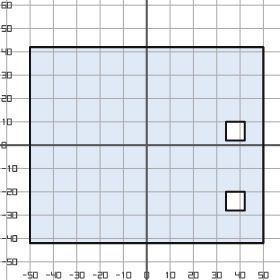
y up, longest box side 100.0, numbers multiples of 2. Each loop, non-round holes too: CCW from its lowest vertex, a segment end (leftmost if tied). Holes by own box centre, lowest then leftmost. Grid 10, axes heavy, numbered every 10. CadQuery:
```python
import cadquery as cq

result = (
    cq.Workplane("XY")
    .moveTo(-50.0, -42.0)
    .lineTo(50.0, -42.0)
    .lineTo(50.0, 42.0)
    .lineTo(-50.0, 42.0)
    .close()
    .moveTo(34.0, -28.0)
    .lineTo(42.0, -28.0)
    .lineTo(42.0, -20.0)
    .lineTo(34.0, -20.0)
    .close()
    .moveTo(34.0, 2.0)
    .lineTo(42.0, 2.0)
    .lineTo(42.0, 10.0)
    .lineTo(34.0, 10.0)
    .close()
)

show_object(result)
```